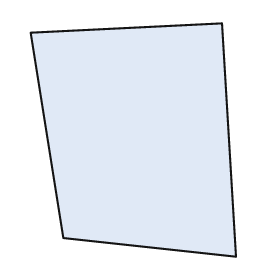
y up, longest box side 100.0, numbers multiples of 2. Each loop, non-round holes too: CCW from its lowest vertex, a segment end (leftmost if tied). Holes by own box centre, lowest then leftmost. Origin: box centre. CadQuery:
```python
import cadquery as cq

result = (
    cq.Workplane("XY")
    .moveTo(44.0, -50.0)
    .lineTo(38.0, 50.0)
    .lineTo(-44.0, 46.0)
    .lineTo(-30.0, -42.0)
    .close()
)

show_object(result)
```